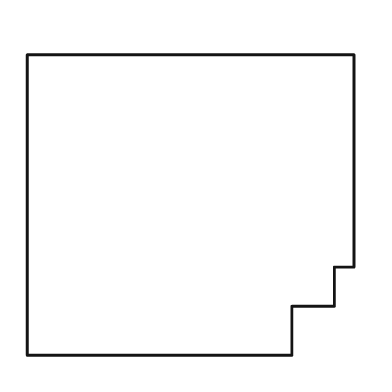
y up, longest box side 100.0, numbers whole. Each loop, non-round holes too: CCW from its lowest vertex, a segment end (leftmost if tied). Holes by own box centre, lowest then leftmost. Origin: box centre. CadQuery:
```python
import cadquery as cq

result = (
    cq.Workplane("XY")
    .moveTo(-50.0, -46.0)
    .lineTo(31.0, -46.0)
    .lineTo(31.0, -31.0)
    .lineTo(44.0, -31.0)
    .lineTo(44.0, -19.0)
    .lineTo(50.0, -19.0)
    .lineTo(50.0, 46.0)
    .lineTo(-50.0, 46.0)
    .close()
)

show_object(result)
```